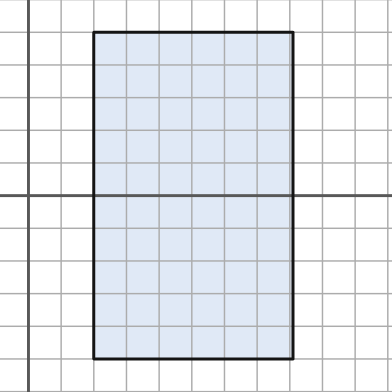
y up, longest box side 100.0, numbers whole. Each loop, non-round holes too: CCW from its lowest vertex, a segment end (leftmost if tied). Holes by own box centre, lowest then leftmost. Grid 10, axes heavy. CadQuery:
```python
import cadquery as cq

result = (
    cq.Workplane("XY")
    .moveTo(20.0, -50.0)
    .lineTo(81.0, -50.0)
    .lineTo(81.0, 50.0)
    .lineTo(20.0, 50.0)
    .close()
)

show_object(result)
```